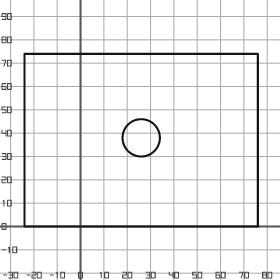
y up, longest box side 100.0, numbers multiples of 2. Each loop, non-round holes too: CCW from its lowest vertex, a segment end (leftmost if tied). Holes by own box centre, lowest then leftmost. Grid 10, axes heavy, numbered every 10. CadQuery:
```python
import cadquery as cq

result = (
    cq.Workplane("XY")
    .moveTo(-24.0, 0.0)
    .lineTo(76.0, 0.0)
    .lineTo(76.0, 74.0)
    .lineTo(-24.0, 74.0)
    .close()
    .moveTo(26.0, 38.0)
    .circle(8.0)
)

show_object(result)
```